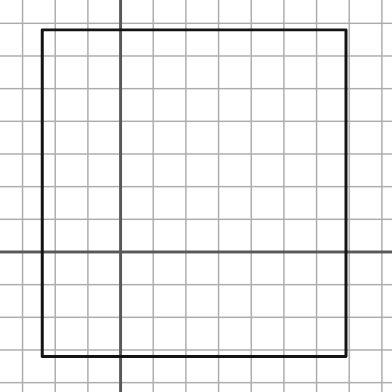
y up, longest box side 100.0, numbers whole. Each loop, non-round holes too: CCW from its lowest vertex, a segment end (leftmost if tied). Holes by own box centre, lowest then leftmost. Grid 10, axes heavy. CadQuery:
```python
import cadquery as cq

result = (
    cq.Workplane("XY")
    .moveTo(-24.0, -32.0)
    .lineTo(69.0, -32.0)
    .lineTo(69.0, 68.0)
    .lineTo(-24.0, 68.0)
    .close()
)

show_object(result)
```